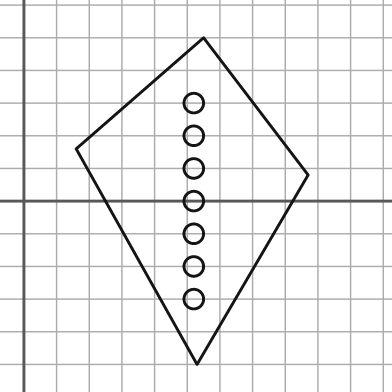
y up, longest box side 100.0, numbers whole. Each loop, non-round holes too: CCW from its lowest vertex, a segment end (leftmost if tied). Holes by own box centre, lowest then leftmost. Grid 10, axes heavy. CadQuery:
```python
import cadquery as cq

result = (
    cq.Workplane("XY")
    .moveTo(53.0, -50.0)
    .lineTo(87.0, 8.0)
    .lineTo(55.0, 50.0)
    .lineTo(16.0, 16.0)
    .close()
    .moveTo(52.0, -30.0)
    .circle(3.0)
    .moveTo(52.0, -20.0)
    .circle(3.0)
    .moveTo(52.0, -10.0)
    .circle(3.0)
    .moveTo(52.0, 0.0)
    .circle(3.0)
    .moveTo(52.0, 10.0)
    .circle(3.0)
    .moveTo(52.0, 20.0)
    .circle(3.0)
    .moveTo(52.0, 30.0)
    .circle(3.0)
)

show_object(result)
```